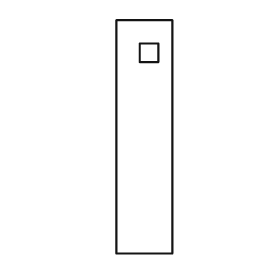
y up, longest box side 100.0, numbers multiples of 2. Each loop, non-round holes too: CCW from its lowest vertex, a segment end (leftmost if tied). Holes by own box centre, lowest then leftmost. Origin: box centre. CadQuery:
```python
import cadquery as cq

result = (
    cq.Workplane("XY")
    .moveTo(-12.0, -50.0)
    .lineTo(12.0, -50.0)
    .lineTo(12.0, 50.0)
    .lineTo(-12.0, 50.0)
    .close()
    .moveTo(-2.0, 32.0)
    .lineTo(6.0, 32.0)
    .lineTo(6.0, 40.0)
    .lineTo(-2.0, 40.0)
    .close()
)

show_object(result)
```